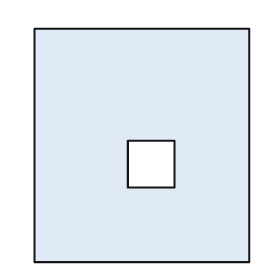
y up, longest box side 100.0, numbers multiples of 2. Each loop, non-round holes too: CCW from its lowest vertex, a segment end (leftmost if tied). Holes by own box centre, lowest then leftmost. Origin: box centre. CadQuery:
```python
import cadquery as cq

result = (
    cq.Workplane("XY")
    .moveTo(-46.0, -50.0)
    .lineTo(46.0, -50.0)
    .lineTo(46.0, 50.0)
    .lineTo(-46.0, 50.0)
    .close()
    .moveTo(-6.0, -18.0)
    .lineTo(14.0, -18.0)
    .lineTo(14.0, 2.0)
    .lineTo(-6.0, 2.0)
    .close()
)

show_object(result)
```